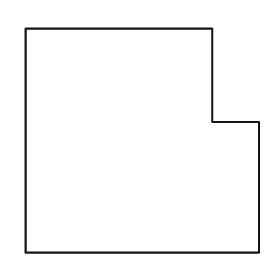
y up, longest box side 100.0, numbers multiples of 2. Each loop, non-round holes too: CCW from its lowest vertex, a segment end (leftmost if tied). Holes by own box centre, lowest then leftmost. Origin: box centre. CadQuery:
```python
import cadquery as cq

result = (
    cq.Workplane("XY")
    .moveTo(-50.0, -48.0)
    .lineTo(50.0, -48.0)
    .lineTo(50.0, 8.0)
    .lineTo(30.0, 8.0)
    .lineTo(30.0, 48.0)
    .lineTo(-50.0, 48.0)
    .close()
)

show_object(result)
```